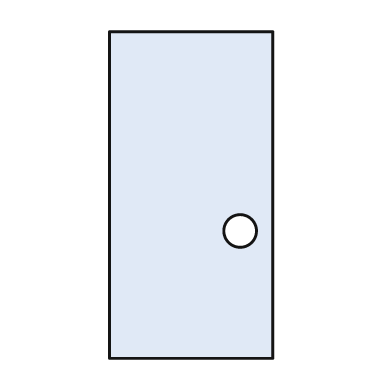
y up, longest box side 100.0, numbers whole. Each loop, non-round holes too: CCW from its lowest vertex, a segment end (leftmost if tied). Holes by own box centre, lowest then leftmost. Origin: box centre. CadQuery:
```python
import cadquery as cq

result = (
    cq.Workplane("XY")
    .moveTo(-25.0, -50.0)
    .lineTo(25.0, -50.0)
    .lineTo(25.0, 50.0)
    .lineTo(-25.0, 50.0)
    .close()
    .moveTo(15.0, -11.0)
    .circle(5.0)
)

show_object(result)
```